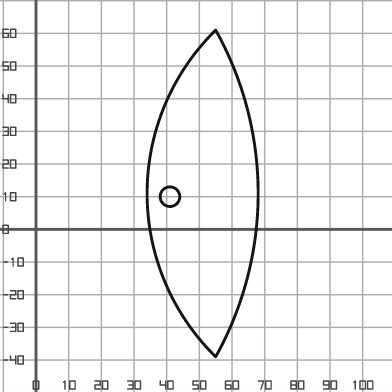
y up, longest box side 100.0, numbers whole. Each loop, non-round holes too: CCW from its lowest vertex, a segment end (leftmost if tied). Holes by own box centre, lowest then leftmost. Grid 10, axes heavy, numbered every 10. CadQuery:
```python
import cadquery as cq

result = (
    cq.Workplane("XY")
    .moveTo(55.0, -39.0)
    .threePointArc((68.0, 11.0), (55.0, 61.0))
    .threePointArc((34.0, 11.0), (55.0, -39.0))
    .close()
    .moveTo(41.0, 10.0)
    .circle(3.0)
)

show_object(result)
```